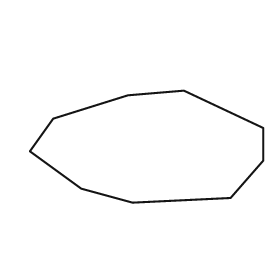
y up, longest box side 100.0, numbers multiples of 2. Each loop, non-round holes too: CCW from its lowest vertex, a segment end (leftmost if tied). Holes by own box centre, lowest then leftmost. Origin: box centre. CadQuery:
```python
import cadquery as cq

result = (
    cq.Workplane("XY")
    .moveTo(-6.0, -24.0)
    .lineTo(36.0, -22.0)
    .lineTo(50.0, -6.0)
    .lineTo(50.0, 8.0)
    .lineTo(16.0, 24.0)
    .lineTo(-8.0, 22.0)
    .lineTo(-40.0, 12.0)
    .lineTo(-50.0, -2.0)
    .lineTo(-28.0, -18.0)
    .close()
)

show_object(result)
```